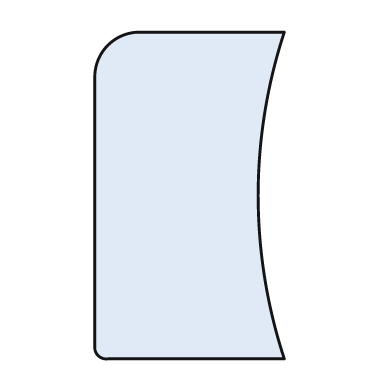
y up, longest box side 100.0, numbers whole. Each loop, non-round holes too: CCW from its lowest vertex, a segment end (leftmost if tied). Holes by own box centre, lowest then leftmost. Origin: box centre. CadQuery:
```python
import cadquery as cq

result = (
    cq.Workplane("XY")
    .moveTo(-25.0, -50.0)
    .lineTo(29.0, -50.0)
    .threePointArc((21.0, 0.0), (29.0, 50.0))
    .lineTo(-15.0, 50.0)
    .threePointArc((-25.0, 46.0), (-29.0, 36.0))
    .lineTo(-29.0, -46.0)
    .threePointArc((-28.0, -49.0), (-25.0, -50.0))
    .close()
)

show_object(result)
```